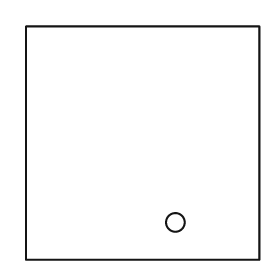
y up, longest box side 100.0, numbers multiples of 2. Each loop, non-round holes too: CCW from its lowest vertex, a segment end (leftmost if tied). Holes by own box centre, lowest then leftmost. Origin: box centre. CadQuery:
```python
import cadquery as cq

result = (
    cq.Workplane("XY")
    .moveTo(-50.0, -50.0)
    .lineTo(50.0, -50.0)
    .lineTo(50.0, 50.0)
    .lineTo(-50.0, 50.0)
    .close()
    .moveTo(14.0, -34.0)
    .circle(4.0)
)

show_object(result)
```